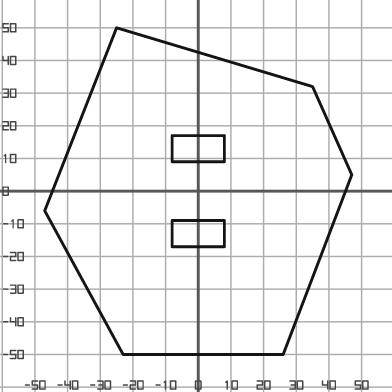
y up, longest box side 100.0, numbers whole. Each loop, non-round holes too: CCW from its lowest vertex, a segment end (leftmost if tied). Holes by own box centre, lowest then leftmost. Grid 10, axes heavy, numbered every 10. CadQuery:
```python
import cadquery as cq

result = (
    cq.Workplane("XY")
    .moveTo(-23.0, -50.0)
    .lineTo(26.0, -50.0)
    .lineTo(47.0, 5.0)
    .lineTo(35.0, 32.0)
    .lineTo(-25.0, 50.0)
    .lineTo(-47.0, -6.0)
    .close()
    .moveTo(-8.0, -17.0)
    .lineTo(8.0, -17.0)
    .lineTo(8.0, -9.0)
    .lineTo(-8.0, -9.0)
    .close()
    .moveTo(-8.0, 9.0)
    .lineTo(8.0, 9.0)
    .lineTo(8.0, 17.0)
    .lineTo(-8.0, 17.0)
    .close()
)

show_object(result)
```